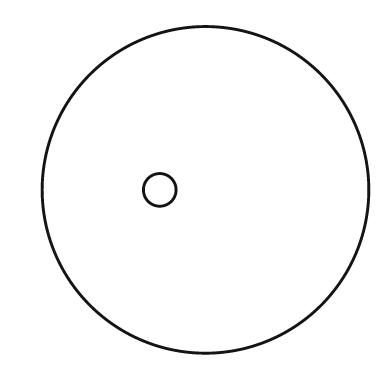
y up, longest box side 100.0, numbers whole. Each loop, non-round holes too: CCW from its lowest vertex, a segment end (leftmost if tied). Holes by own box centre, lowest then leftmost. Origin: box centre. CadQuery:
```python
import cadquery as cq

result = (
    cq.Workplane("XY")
    .moveTo(0.0, 0.0)
    .circle(50.0)
    .moveTo(-14.0, 0.0)
    .circle(5.0)
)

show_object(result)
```